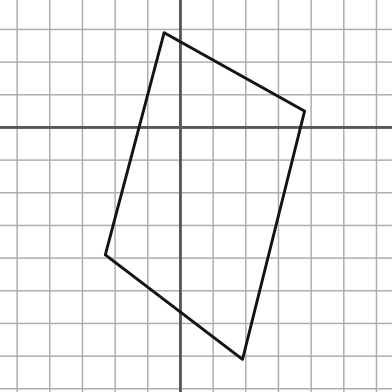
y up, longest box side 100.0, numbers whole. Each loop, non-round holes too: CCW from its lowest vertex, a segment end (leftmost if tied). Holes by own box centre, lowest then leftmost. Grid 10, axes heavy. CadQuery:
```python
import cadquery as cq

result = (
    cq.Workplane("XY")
    .moveTo(19.0, -71.0)
    .lineTo(38.0, 5.0)
    .lineTo(-5.0, 29.0)
    .lineTo(-23.0, -39.0)
    .close()
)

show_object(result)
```